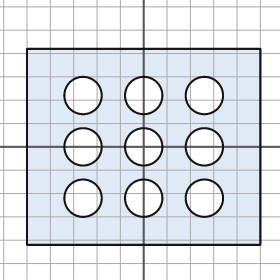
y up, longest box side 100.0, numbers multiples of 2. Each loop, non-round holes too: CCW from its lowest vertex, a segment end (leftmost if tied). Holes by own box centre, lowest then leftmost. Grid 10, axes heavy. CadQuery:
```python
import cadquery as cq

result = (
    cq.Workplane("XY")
    .moveTo(-50.0, -42.0)
    .lineTo(50.0, -42.0)
    .lineTo(50.0, 42.0)
    .lineTo(-50.0, 42.0)
    .close()
    .moveTo(-26.0, -22.0)
    .circle(8.0)
    .moveTo(0.0, -22.0)
    .circle(8.0)
    .moveTo(26.0, -22.0)
    .circle(8.0)
    .moveTo(-26.0, 0.0)
    .circle(8.0)
    .moveTo(0.0, 0.0)
    .circle(8.0)
    .moveTo(26.0, 0.0)
    .circle(8.0)
    .moveTo(-26.0, 22.0)
    .circle(8.0)
    .moveTo(0.0, 22.0)
    .circle(8.0)
    .moveTo(26.0, 22.0)
    .circle(8.0)
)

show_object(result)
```